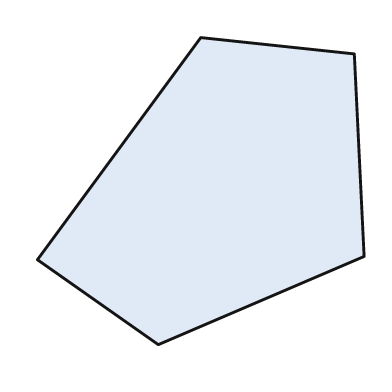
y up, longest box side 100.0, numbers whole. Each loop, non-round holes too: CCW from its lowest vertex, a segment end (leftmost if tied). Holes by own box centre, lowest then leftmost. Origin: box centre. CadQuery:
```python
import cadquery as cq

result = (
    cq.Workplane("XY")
    .moveTo(-13.0, -47.0)
    .lineTo(50.0, -20.0)
    .lineTo(47.0, 42.0)
    .lineTo(0.0, 47.0)
    .lineTo(-50.0, -21.0)
    .close()
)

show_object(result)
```